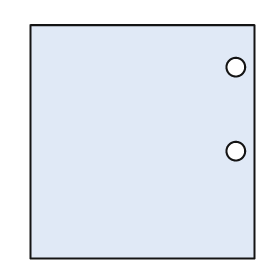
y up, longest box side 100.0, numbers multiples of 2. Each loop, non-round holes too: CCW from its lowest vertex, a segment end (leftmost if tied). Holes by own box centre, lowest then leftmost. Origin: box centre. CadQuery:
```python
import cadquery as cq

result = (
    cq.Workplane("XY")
    .moveTo(-48.0, -50.0)
    .lineTo(48.0, -50.0)
    .lineTo(48.0, 50.0)
    .lineTo(-48.0, 50.0)
    .close()
    .moveTo(40.0, -4.0)
    .circle(4.0)
    .moveTo(40.0, 32.0)
    .circle(4.0)
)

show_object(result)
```